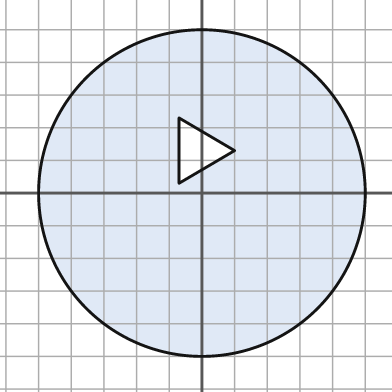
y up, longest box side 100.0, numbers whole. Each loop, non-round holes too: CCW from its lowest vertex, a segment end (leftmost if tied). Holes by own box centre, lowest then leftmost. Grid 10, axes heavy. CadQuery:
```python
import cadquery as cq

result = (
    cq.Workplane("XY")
    .moveTo(0.0, 0.0)
    .circle(50.0)
    .moveTo(-7.0, 3.0)
    .lineTo(10.0, 13.0)
    .lineTo(-7.0, 23.0)
    .close()
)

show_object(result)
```